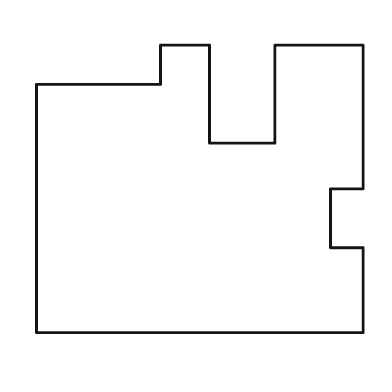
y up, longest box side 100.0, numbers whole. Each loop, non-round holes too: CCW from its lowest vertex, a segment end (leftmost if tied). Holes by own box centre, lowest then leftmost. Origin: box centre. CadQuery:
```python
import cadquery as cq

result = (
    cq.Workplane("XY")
    .moveTo(-50.0, -44.0)
    .lineTo(50.0, -44.0)
    .lineTo(50.0, -18.0)
    .lineTo(40.0, -18.0)
    .lineTo(40.0, 0.0)
    .lineTo(50.0, 0.0)
    .lineTo(50.0, 44.0)
    .lineTo(23.0, 44.0)
    .lineTo(23.0, 14.0)
    .lineTo(3.0, 14.0)
    .lineTo(3.0, 44.0)
    .lineTo(-12.0, 44.0)
    .lineTo(-12.0, 32.0)
    .lineTo(-50.0, 32.0)
    .close()
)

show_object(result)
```